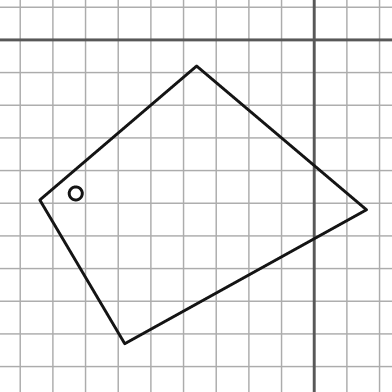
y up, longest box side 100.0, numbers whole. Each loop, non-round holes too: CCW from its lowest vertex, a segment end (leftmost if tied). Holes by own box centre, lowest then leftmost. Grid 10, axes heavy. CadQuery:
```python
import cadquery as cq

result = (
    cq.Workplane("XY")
    .moveTo(-58.0, -93.0)
    .lineTo(16.0, -52.0)
    .lineTo(-36.0, -8.0)
    .lineTo(-84.0, -49.0)
    .close()
    .moveTo(-73.0, -47.0)
    .circle(2.0)
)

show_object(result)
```